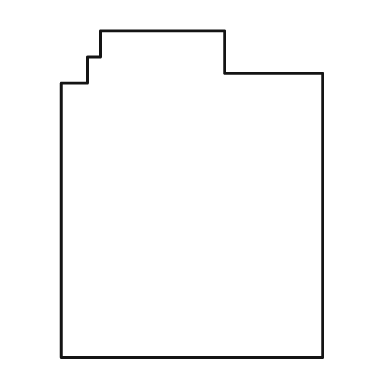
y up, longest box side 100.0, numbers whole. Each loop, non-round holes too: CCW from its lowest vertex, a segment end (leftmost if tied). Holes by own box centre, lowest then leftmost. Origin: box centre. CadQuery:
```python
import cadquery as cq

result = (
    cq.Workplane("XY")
    .moveTo(-40.0, -50.0)
    .lineTo(40.0, -50.0)
    .lineTo(40.0, 37.0)
    .lineTo(10.0, 37.0)
    .lineTo(10.0, 50.0)
    .lineTo(-28.0, 50.0)
    .lineTo(-28.0, 42.0)
    .lineTo(-32.0, 42.0)
    .lineTo(-32.0, 34.0)
    .lineTo(-40.0, 34.0)
    .close()
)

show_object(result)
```